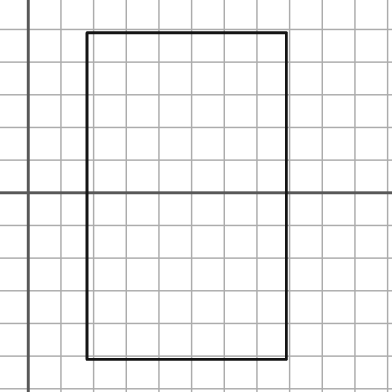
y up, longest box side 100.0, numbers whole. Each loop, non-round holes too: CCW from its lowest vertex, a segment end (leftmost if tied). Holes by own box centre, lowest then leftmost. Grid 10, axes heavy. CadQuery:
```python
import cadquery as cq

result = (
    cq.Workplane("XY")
    .moveTo(18.0, -51.0)
    .lineTo(79.0, -51.0)
    .lineTo(79.0, 49.0)
    .lineTo(18.0, 49.0)
    .close()
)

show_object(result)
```